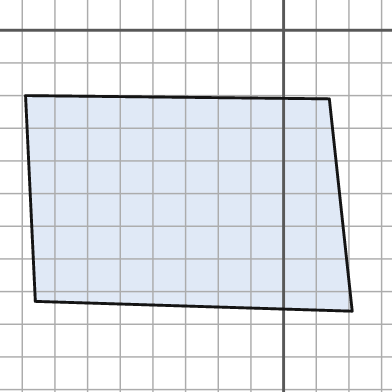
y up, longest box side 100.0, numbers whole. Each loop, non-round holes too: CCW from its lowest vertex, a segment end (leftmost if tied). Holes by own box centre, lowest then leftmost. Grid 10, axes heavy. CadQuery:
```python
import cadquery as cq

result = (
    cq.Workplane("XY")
    .moveTo(21.0, -86.0)
    .lineTo(14.0, -21.0)
    .lineTo(-79.0, -20.0)
    .lineTo(-76.0, -83.0)
    .close()
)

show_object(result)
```